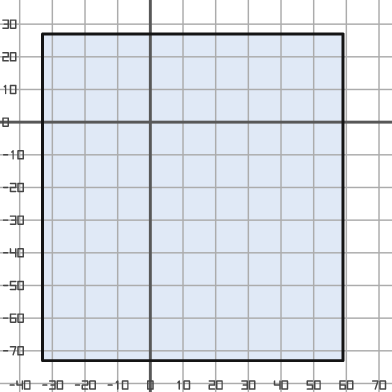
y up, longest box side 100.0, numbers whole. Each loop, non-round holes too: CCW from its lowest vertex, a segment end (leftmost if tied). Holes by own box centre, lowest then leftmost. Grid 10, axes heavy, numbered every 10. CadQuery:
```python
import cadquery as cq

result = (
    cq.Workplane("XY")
    .moveTo(-33.0, -73.0)
    .lineTo(59.0, -73.0)
    .lineTo(59.0, 27.0)
    .lineTo(-33.0, 27.0)
    .close()
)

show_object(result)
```